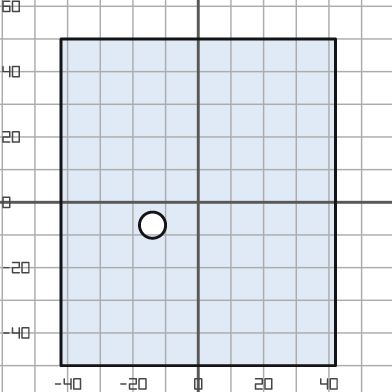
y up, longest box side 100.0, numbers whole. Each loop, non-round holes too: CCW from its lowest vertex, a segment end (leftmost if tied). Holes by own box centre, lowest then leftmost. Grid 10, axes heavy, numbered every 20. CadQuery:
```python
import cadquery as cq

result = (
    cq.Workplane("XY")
    .moveTo(-42.0, -50.0)
    .lineTo(42.0, -50.0)
    .lineTo(42.0, 50.0)
    .lineTo(-42.0, 50.0)
    .close()
    .moveTo(-14.0, -7.0)
    .circle(4.0)
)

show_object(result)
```